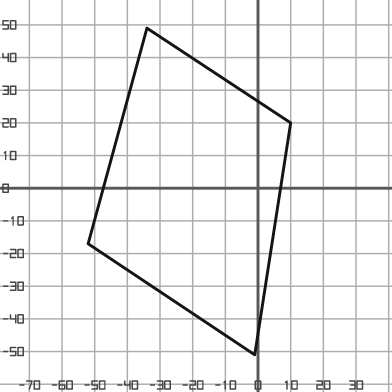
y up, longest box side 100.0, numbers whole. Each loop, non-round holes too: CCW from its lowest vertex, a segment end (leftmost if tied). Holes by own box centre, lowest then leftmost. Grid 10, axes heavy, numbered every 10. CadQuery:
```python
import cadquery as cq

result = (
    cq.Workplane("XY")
    .moveTo(-1.0, -51.0)
    .lineTo(10.0, 20.0)
    .lineTo(-34.0, 49.0)
    .lineTo(-52.0, -17.0)
    .close()
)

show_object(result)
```